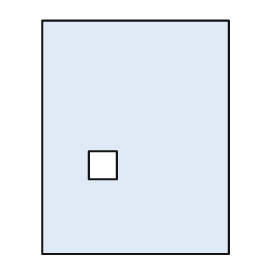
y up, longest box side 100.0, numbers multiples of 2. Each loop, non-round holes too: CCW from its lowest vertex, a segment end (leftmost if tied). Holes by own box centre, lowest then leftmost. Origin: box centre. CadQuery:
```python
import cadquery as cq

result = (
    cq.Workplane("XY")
    .moveTo(-40.0, -50.0)
    .lineTo(40.0, -50.0)
    .lineTo(40.0, 50.0)
    .lineTo(-40.0, 50.0)
    .close()
    .moveTo(-20.0, -18.0)
    .lineTo(-8.0, -18.0)
    .lineTo(-8.0, -6.0)
    .lineTo(-20.0, -6.0)
    .close()
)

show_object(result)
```